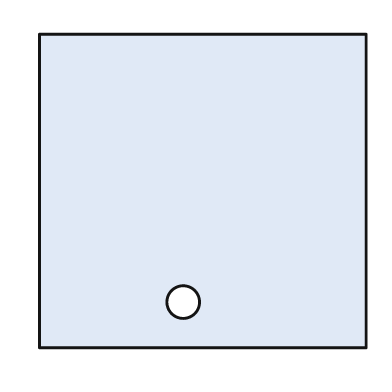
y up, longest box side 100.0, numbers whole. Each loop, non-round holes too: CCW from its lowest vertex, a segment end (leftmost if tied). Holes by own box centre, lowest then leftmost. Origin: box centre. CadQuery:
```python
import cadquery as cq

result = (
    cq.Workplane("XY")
    .moveTo(-50.0, -48.0)
    .lineTo(50.0, -48.0)
    .lineTo(50.0, 48.0)
    .lineTo(-50.0, 48.0)
    .close()
    .moveTo(-6.0, -34.0)
    .circle(5.0)
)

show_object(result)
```